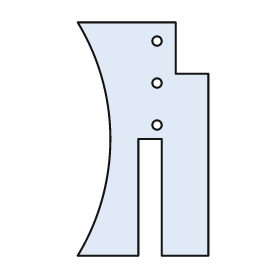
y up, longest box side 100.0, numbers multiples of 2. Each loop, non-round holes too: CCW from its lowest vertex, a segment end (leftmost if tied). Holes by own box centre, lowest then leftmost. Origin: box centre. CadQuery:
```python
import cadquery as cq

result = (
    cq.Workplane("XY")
    .moveTo(-28.0, -50.0)
    .lineTo(-2.0, -50.0)
    .lineTo(-2.0, 0.0)
    .lineTo(8.0, 0.0)
    .lineTo(8.0, -50.0)
    .lineTo(28.0, -50.0)
    .lineTo(28.0, 28.0)
    .lineTo(14.0, 28.0)
    .lineTo(14.0, 50.0)
    .lineTo(-28.0, 50.0)
    .threePointArc((-14.0, 0.0), (-28.0, -50.0))
    .close()
    .moveTo(6.0, 6.0)
    .circle(2.0)
    .moveTo(6.0, 24.0)
    .circle(2.0)
    .moveTo(6.0, 42.0)
    .circle(2.0)
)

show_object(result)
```